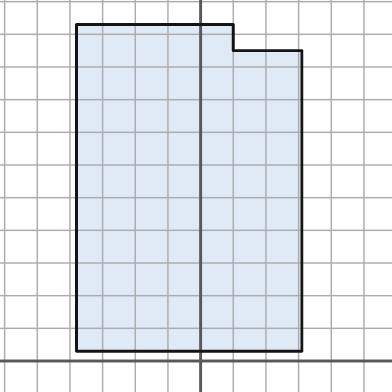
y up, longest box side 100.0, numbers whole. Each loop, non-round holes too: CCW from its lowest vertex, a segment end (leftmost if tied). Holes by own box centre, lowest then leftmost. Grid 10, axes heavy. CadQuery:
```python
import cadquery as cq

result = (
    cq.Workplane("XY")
    .moveTo(-38.0, 3.0)
    .lineTo(31.0, 3.0)
    .lineTo(31.0, 95.0)
    .lineTo(10.0, 95.0)
    .lineTo(10.0, 103.0)
    .lineTo(-38.0, 103.0)
    .close()
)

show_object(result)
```